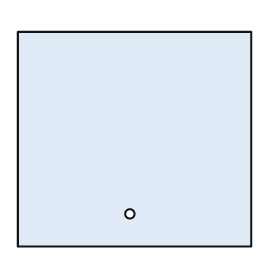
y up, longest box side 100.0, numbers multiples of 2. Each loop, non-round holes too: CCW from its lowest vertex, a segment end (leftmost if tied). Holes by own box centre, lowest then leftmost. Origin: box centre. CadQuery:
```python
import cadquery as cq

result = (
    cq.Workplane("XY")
    .moveTo(-50.0, -46.0)
    .lineTo(50.0, -46.0)
    .lineTo(50.0, 46.0)
    .lineTo(-50.0, 46.0)
    .close()
    .moveTo(-2.0, -32.0)
    .circle(2.0)
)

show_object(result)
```